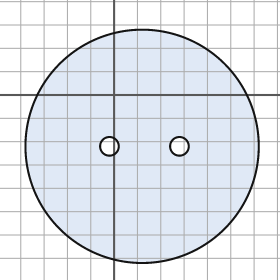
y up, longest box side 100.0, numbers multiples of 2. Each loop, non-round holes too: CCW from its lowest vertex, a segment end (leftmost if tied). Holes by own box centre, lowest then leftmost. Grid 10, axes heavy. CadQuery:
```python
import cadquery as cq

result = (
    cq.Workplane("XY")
    .moveTo(12.0, -22.0)
    .circle(50.0)
    .moveTo(-2.0, -22.0)
    .circle(4.0)
    .moveTo(28.0, -22.0)
    .circle(4.0)
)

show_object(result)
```